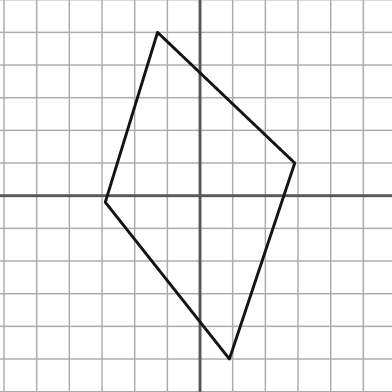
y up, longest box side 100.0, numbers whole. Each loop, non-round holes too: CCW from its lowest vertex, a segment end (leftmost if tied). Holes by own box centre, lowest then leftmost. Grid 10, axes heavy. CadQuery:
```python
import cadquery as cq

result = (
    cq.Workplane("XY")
    .moveTo(9.0, -50.0)
    .lineTo(29.0, 10.0)
    .lineTo(-13.0, 50.0)
    .lineTo(-29.0, -2.0)
    .close()
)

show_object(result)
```